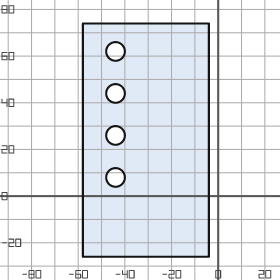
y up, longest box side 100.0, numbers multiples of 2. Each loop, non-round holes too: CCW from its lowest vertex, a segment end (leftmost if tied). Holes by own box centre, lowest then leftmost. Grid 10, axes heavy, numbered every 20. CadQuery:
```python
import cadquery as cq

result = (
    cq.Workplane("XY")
    .moveTo(-58.0, -26.0)
    .lineTo(-4.0, -26.0)
    .lineTo(-4.0, 74.0)
    .lineTo(-58.0, 74.0)
    .close()
    .moveTo(-44.0, 8.0)
    .circle(4.0)
    .moveTo(-44.0, 26.0)
    .circle(4.0)
    .moveTo(-44.0, 44.0)
    .circle(4.0)
    .moveTo(-44.0, 62.0)
    .circle(4.0)
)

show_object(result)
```